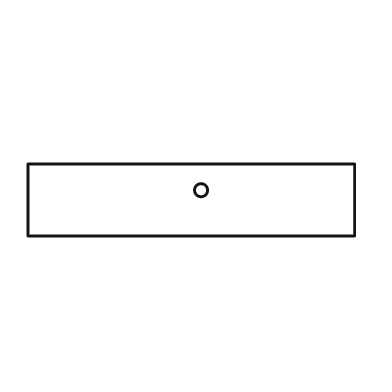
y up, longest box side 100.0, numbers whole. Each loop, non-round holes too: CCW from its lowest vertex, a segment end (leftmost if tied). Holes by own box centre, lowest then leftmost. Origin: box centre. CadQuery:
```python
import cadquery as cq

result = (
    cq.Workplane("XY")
    .moveTo(-50.0, -11.0)
    .lineTo(50.0, -11.0)
    .lineTo(50.0, 11.0)
    .lineTo(-50.0, 11.0)
    .close()
    .moveTo(3.0, 3.0)
    .circle(2.0)
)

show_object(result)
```